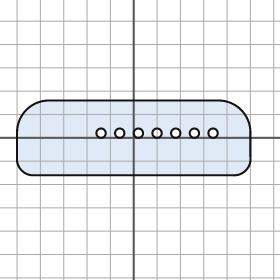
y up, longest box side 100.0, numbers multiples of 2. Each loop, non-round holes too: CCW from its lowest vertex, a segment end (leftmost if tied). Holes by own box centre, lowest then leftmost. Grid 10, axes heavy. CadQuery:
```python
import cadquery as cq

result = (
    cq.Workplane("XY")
    .moveTo(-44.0, -16.0)
    .lineTo(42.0, -16.0)
    .threePointArc((48.0, -14.0), (50.0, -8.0))
    .lineTo(50.0, 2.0)
    .threePointArc((46.0, 12.0), (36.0, 16.0))
    .lineTo(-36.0, 16.0)
    .threePointArc((-46.0, 12.0), (-50.0, 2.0))
    .lineTo(-50.0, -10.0)
    .threePointArc((-48.0, -14.0), (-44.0, -16.0))
    .close()
    .moveTo(-14.0, 2.0)
    .circle(2.0)
    .moveTo(-6.0, 2.0)
    .circle(2.0)
    .moveTo(2.0, 2.0)
    .circle(2.0)
    .moveTo(10.0, 2.0)
    .circle(2.0)
    .moveTo(18.0, 2.0)
    .circle(2.0)
    .moveTo(26.0, 2.0)
    .circle(2.0)
    .moveTo(34.0, 2.0)
    .circle(2.0)
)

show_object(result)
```